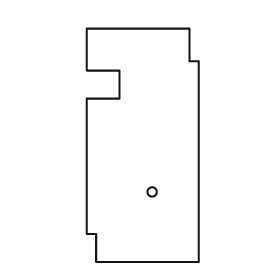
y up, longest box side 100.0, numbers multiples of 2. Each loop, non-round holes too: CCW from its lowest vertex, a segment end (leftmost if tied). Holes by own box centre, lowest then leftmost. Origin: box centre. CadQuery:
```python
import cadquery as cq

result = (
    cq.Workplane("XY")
    .moveTo(-20.0, -50.0)
    .lineTo(24.0, -50.0)
    .lineTo(24.0, 36.0)
    .lineTo(20.0, 36.0)
    .lineTo(20.0, 50.0)
    .lineTo(-24.0, 50.0)
    .lineTo(-24.0, 32.0)
    .lineTo(-10.0, 32.0)
    .lineTo(-10.0, 20.0)
    .lineTo(-24.0, 20.0)
    .lineTo(-24.0, -38.0)
    .lineTo(-20.0, -38.0)
    .close()
    .moveTo(4.0, -20.0)
    .circle(2.0)
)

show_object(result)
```